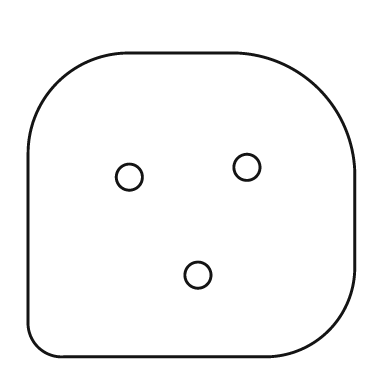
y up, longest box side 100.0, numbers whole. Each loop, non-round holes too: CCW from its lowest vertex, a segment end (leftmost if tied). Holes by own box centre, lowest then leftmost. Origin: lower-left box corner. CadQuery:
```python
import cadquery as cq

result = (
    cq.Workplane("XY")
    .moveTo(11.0, 0.0)
    .lineTo(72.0, 0.0)
    .threePointArc((92.0, 8.0), (100.0, 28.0))
    .lineTo(100.0, 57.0)
    .threePointArc((89.0, 82.0), (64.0, 93.0))
    .lineTo(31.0, 93.0)
    .threePointArc((9.0, 84.0), (0.0, 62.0))
    .lineTo(0.0, 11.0)
    .threePointArc((3.0, 3.0), (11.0, 0.0))
    .close()
    .moveTo(52.0, 25.0)
    .circle(4.0)
    .moveTo(31.0, 55.0)
    .circle(4.0)
    .moveTo(67.0, 58.0)
    .circle(4.0)
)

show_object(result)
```